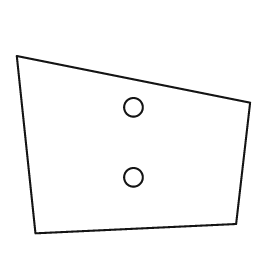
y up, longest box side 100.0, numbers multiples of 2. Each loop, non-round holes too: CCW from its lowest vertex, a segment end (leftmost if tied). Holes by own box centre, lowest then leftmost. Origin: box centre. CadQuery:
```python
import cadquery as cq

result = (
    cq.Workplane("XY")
    .moveTo(-42.0, -38.0)
    .lineTo(44.0, -34.0)
    .lineTo(50.0, 18.0)
    .lineTo(-50.0, 38.0)
    .close()
    .moveTo(0.0, -14.0)
    .circle(4.0)
    .moveTo(0.0, 16.0)
    .circle(4.0)
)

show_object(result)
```